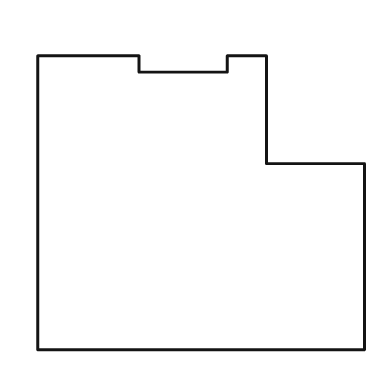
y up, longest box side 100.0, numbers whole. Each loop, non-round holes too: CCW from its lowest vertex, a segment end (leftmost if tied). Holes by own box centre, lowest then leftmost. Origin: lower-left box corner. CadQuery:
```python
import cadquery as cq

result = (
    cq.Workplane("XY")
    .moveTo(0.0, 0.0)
    .lineTo(100.0, 0.0)
    .lineTo(100.0, 57.0)
    .lineTo(70.0, 57.0)
    .lineTo(70.0, 90.0)
    .lineTo(58.0, 90.0)
    .lineTo(58.0, 85.0)
    .lineTo(31.0, 85.0)
    .lineTo(31.0, 90.0)
    .lineTo(0.0, 90.0)
    .close()
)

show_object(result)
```